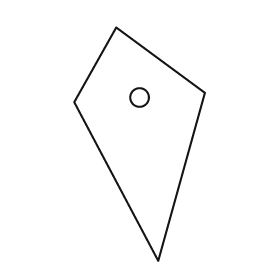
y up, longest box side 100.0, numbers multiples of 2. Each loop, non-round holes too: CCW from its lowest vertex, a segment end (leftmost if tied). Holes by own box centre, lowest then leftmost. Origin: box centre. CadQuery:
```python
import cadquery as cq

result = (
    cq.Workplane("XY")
    .moveTo(8.0, -50.0)
    .lineTo(28.0, 22.0)
    .lineTo(-10.0, 50.0)
    .lineTo(-28.0, 18.0)
    .close()
    .moveTo(0.0, 20.0)
    .circle(4.0)
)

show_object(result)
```